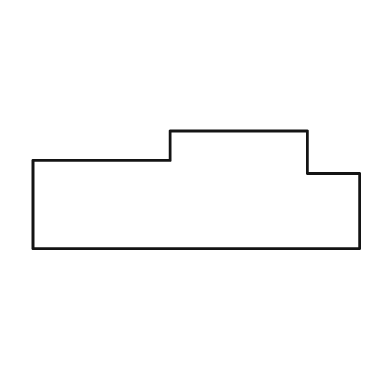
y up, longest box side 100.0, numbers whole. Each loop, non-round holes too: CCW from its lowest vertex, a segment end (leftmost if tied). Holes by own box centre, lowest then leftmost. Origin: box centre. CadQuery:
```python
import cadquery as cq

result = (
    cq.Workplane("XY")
    .moveTo(-50.0, -18.0)
    .lineTo(50.0, -18.0)
    .lineTo(50.0, 5.0)
    .lineTo(34.0, 5.0)
    .lineTo(34.0, 18.0)
    .lineTo(-8.0, 18.0)
    .lineTo(-8.0, 9.0)
    .lineTo(-50.0, 9.0)
    .close()
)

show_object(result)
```